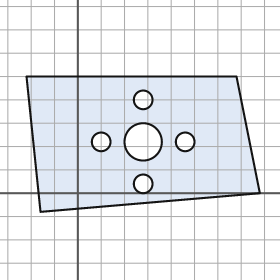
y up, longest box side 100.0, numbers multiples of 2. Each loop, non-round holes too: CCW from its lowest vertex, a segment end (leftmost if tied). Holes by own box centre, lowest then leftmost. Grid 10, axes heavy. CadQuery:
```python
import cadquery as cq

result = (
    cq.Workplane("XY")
    .moveTo(-16.0, -8.0)
    .lineTo(78.0, 0.0)
    .lineTo(68.0, 50.0)
    .lineTo(-22.0, 50.0)
    .close()
    .moveTo(28.0, 4.0)
    .circle(4.0)
    .moveTo(10.0, 22.0)
    .circle(4.0)
    .moveTo(28.0, 22.0)
    .circle(8.0)
    .moveTo(46.0, 22.0)
    .circle(4.0)
    .moveTo(28.0, 40.0)
    .circle(4.0)
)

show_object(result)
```